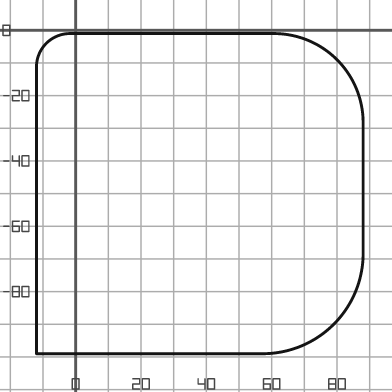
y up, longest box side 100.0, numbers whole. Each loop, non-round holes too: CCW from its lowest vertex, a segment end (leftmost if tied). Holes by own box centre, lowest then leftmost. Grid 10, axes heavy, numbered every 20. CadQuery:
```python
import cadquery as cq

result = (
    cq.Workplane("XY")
    .moveTo(-12.0, -99.0)
    .lineTo(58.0, -99.0)
    .threePointArc((79.0, -90.0), (88.0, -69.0))
    .lineTo(88.0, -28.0)
    .threePointArc((80.0, -9.0), (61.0, -1.0))
    .lineTo(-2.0, -1.0)
    .threePointArc((-9.0, -4.0), (-12.0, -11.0))
    .close()
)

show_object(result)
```